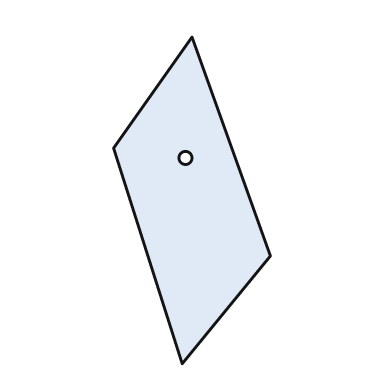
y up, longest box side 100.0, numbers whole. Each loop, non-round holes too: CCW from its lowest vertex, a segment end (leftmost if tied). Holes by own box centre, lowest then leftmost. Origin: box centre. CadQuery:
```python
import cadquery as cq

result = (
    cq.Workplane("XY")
    .moveTo(-3.0, -50.0)
    .lineTo(24.0, -17.0)
    .lineTo(0.0, 50.0)
    .lineTo(-24.0, 16.0)
    .close()
    .moveTo(-2.0, 13.0)
    .circle(2.0)
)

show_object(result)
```